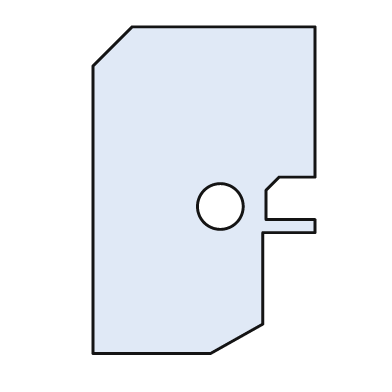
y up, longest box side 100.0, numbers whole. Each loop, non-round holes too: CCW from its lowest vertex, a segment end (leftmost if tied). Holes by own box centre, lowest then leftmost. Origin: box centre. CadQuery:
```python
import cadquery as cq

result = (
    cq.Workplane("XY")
    .moveTo(-34.0, -50.0)
    .lineTo(2.0, -50.0)
    .lineTo(18.0, -41.0)
    .lineTo(18.0, -13.0)
    .lineTo(34.0, -13.0)
    .lineTo(34.0, -9.0)
    .lineTo(19.0, -9.0)
    .lineTo(19.0, 0.0)
    .lineTo(23.0, 4.0)
    .lineTo(34.0, 4.0)
    .lineTo(34.0, 50.0)
    .lineTo(-22.0, 50.0)
    .lineTo(-34.0, 38.0)
    .close()
    .moveTo(5.0, -5.0)
    .circle(7.0)
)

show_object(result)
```